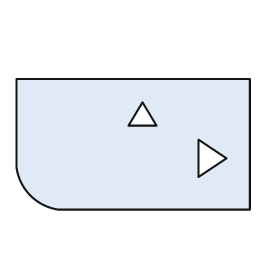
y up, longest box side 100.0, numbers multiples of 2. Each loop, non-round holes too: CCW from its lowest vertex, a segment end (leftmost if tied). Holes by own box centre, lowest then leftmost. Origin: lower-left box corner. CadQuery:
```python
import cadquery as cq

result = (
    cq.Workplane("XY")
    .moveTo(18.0, 0.0)
    .lineTo(100.0, 0.0)
    .lineTo(100.0, 56.0)
    .lineTo(0.0, 56.0)
    .lineTo(0.0, 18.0)
    .threePointArc((6.0, 6.0), (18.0, 0.0))
    .close()
    .moveTo(78.0, 14.0)
    .lineTo(90.0, 22.0)
    .lineTo(78.0, 30.0)
    .close()
    .moveTo(48.0, 36.0)
    .lineTo(60.0, 36.0)
    .lineTo(54.0, 46.0)
    .close()
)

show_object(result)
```